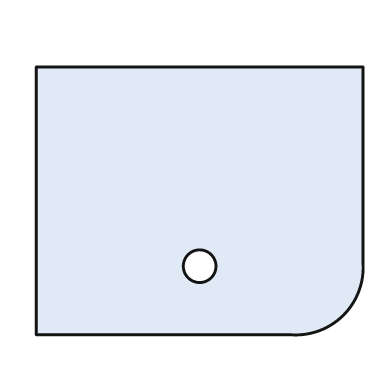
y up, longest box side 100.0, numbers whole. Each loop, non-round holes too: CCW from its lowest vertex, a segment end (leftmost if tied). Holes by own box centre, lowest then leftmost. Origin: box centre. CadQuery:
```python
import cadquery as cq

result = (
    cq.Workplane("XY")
    .moveTo(-50.0, -41.0)
    .lineTo(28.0, -41.0)
    .threePointArc((44.0, -35.0), (50.0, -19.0))
    .lineTo(50.0, 41.0)
    .lineTo(-50.0, 41.0)
    .close()
    .moveTo(0.0, -20.0)
    .circle(5.0)
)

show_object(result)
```